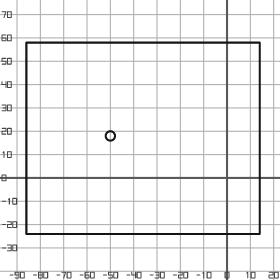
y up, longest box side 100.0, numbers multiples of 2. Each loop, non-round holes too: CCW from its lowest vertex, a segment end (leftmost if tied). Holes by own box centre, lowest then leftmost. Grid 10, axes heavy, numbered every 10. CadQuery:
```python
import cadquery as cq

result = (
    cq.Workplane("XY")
    .moveTo(-86.0, -24.0)
    .lineTo(14.0, -24.0)
    .lineTo(14.0, 58.0)
    .lineTo(-86.0, 58.0)
    .close()
    .moveTo(-50.0, 18.0)
    .circle(2.0)
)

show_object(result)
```